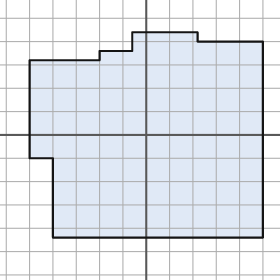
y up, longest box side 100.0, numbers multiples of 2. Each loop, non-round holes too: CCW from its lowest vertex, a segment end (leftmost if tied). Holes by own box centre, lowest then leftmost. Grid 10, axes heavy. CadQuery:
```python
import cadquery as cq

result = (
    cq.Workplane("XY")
    .moveTo(-40.0, -44.0)
    .lineTo(50.0, -44.0)
    .lineTo(50.0, 40.0)
    .lineTo(22.0, 40.0)
    .lineTo(22.0, 44.0)
    .lineTo(-6.0, 44.0)
    .lineTo(-6.0, 36.0)
    .lineTo(-20.0, 36.0)
    .lineTo(-20.0, 32.0)
    .lineTo(-50.0, 32.0)
    .lineTo(-50.0, -10.0)
    .lineTo(-40.0, -10.0)
    .close()
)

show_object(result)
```